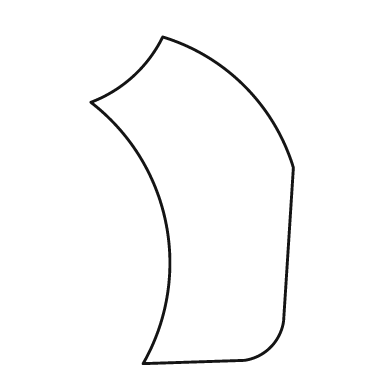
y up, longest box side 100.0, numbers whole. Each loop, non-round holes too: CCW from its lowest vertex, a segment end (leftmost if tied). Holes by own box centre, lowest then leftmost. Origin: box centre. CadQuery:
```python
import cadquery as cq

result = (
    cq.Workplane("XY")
    .moveTo(-15.0, -50.0)
    .lineTo(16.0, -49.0)
    .threePointArc((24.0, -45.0), (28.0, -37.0))
    .lineTo(31.0, 10.0)
    .threePointArc((16.0, 35.0), (-9.0, 50.0))
    .threePointArc((-18.0, 38.0), (-31.0, 30.0))
    .threePointArc((-8.0, -7.0), (-15.0, -50.0))
    .close()
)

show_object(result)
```